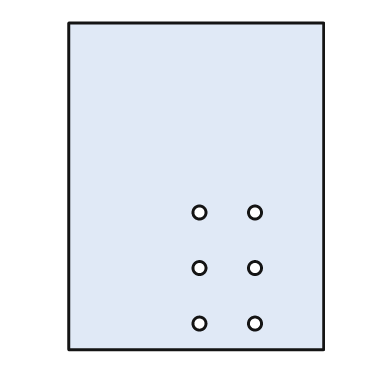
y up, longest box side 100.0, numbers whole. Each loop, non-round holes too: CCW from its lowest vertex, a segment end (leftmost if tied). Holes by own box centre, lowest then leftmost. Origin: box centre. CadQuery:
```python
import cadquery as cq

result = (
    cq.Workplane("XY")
    .moveTo(-39.0, -50.0)
    .lineTo(39.0, -50.0)
    .lineTo(39.0, 50.0)
    .lineTo(-39.0, 50.0)
    .close()
    .moveTo(1.0, -42.0)
    .circle(2.0)
    .moveTo(18.0, -42.0)
    .circle(2.0)
    .moveTo(1.0, -25.0)
    .circle(2.0)
    .moveTo(18.0, -25.0)
    .circle(2.0)
    .moveTo(1.0, -8.0)
    .circle(2.0)
    .moveTo(18.0, -8.0)
    .circle(2.0)
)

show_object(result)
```